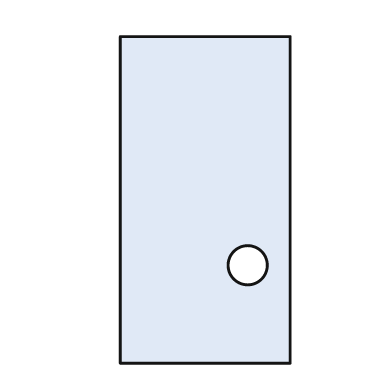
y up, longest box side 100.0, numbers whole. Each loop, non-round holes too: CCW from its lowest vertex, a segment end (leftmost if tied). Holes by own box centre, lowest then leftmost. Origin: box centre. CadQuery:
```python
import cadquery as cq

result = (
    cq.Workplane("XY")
    .moveTo(-26.0, -50.0)
    .lineTo(26.0, -50.0)
    .lineTo(26.0, 50.0)
    .lineTo(-26.0, 50.0)
    .close()
    .moveTo(13.0, -20.0)
    .circle(6.0)
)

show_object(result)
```